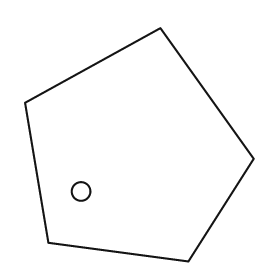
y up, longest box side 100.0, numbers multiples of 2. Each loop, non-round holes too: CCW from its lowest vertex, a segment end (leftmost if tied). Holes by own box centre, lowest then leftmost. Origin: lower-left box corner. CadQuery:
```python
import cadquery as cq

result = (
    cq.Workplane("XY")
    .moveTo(70.0, 0.0)
    .lineTo(98.0, 44.0)
    .lineTo(58.0, 100.0)
    .lineTo(0.0, 68.0)
    .lineTo(10.0, 8.0)
    .close()
    .moveTo(24.0, 30.0)
    .circle(4.0)
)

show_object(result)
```